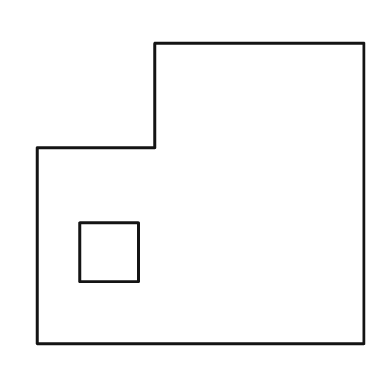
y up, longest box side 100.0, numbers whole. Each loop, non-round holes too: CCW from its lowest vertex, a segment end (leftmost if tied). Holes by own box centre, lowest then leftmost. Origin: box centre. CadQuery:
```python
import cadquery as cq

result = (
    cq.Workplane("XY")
    .moveTo(-50.0, -46.0)
    .lineTo(50.0, -46.0)
    .lineTo(50.0, 46.0)
    .lineTo(-14.0, 46.0)
    .lineTo(-14.0, 14.0)
    .lineTo(-50.0, 14.0)
    .close()
    .moveTo(-37.0, -27.0)
    .lineTo(-19.0, -27.0)
    .lineTo(-19.0, -9.0)
    .lineTo(-37.0, -9.0)
    .close()
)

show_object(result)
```